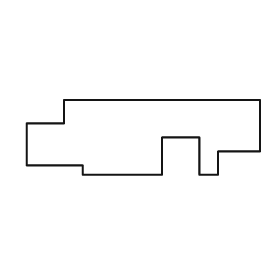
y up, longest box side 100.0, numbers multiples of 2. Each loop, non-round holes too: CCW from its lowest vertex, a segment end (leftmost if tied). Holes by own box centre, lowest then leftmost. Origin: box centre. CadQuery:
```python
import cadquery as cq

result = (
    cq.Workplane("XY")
    .moveTo(-26.0, -16.0)
    .lineTo(8.0, -16.0)
    .lineTo(8.0, 0.0)
    .lineTo(24.0, 0.0)
    .lineTo(24.0, -16.0)
    .lineTo(32.0, -16.0)
    .lineTo(32.0, -6.0)
    .lineTo(50.0, -6.0)
    .lineTo(50.0, 16.0)
    .lineTo(-34.0, 16.0)
    .lineTo(-34.0, 6.0)
    .lineTo(-50.0, 6.0)
    .lineTo(-50.0, -12.0)
    .lineTo(-26.0, -12.0)
    .close()
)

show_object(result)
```